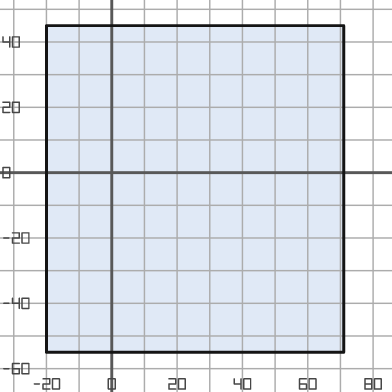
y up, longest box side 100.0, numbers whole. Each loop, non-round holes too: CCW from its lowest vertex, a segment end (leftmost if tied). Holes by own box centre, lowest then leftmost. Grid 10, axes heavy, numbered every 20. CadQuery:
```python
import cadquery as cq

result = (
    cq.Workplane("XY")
    .moveTo(-20.0, -55.0)
    .lineTo(71.0, -55.0)
    .lineTo(71.0, 45.0)
    .lineTo(-20.0, 45.0)
    .close()
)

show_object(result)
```